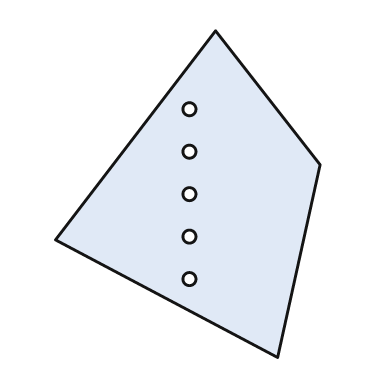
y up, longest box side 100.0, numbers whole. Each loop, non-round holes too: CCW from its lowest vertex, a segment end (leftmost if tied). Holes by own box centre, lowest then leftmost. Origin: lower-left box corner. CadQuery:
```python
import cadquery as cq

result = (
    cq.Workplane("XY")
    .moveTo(68.0, 0.0)
    .lineTo(81.0, 59.0)
    .lineTo(49.0, 100.0)
    .lineTo(0.0, 36.0)
    .close()
    .moveTo(41.0, 24.0)
    .circle(2.0)
    .moveTo(41.0, 37.0)
    .circle(2.0)
    .moveTo(41.0, 50.0)
    .circle(2.0)
    .moveTo(41.0, 63.0)
    .circle(2.0)
    .moveTo(41.0, 76.0)
    .circle(2.0)
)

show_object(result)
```